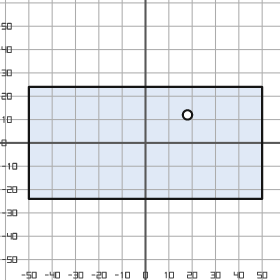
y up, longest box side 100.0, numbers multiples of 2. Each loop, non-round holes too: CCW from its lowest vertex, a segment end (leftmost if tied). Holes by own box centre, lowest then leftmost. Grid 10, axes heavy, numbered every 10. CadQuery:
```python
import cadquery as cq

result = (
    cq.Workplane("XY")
    .moveTo(-50.0, -24.0)
    .lineTo(50.0, -24.0)
    .lineTo(50.0, 24.0)
    .lineTo(-50.0, 24.0)
    .close()
    .moveTo(18.0, 12.0)
    .circle(2.0)
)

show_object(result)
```